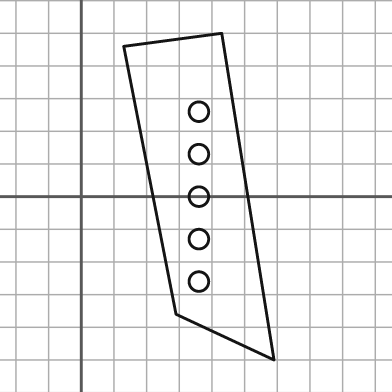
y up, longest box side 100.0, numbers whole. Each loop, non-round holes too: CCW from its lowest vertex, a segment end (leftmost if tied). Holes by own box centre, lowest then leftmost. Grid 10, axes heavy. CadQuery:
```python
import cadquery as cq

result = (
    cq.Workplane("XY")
    .moveTo(59.0, -50.0)
    .lineTo(43.0, 50.0)
    .lineTo(13.0, 46.0)
    .lineTo(29.0, -36.0)
    .close()
    .moveTo(36.0, -26.0)
    .circle(3.0)
    .moveTo(36.0, -13.0)
    .circle(3.0)
    .moveTo(36.0, 0.0)
    .circle(3.0)
    .moveTo(36.0, 13.0)
    .circle(3.0)
    .moveTo(36.0, 26.0)
    .circle(3.0)
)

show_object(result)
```